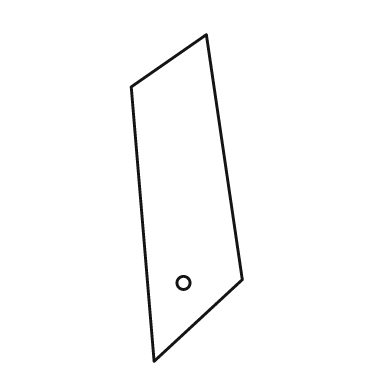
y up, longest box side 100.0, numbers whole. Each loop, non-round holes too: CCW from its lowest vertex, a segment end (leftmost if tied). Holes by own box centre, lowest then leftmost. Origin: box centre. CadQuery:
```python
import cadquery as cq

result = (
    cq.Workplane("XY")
    .moveTo(-10.0, -50.0)
    .lineTo(17.0, -25.0)
    .lineTo(6.0, 50.0)
    .lineTo(-17.0, 34.0)
    .close()
    .moveTo(-1.0, -26.0)
    .circle(2.0)
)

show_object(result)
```